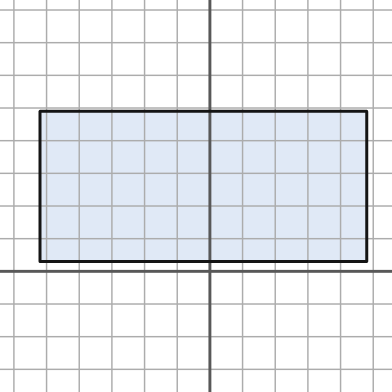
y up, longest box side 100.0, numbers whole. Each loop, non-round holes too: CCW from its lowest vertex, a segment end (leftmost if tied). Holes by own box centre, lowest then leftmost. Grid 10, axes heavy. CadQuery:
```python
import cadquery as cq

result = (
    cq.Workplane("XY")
    .moveTo(-52.0, 3.0)
    .lineTo(48.0, 3.0)
    .lineTo(48.0, 49.0)
    .lineTo(-52.0, 49.0)
    .close()
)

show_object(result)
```